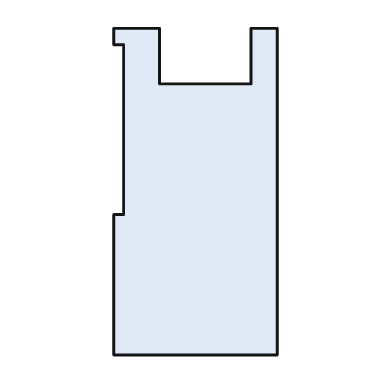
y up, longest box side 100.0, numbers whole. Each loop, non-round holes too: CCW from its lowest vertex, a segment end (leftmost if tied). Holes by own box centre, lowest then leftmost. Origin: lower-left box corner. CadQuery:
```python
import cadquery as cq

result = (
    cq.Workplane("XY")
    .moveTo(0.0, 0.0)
    .lineTo(50.0, 0.0)
    .lineTo(50.0, 100.0)
    .lineTo(42.0, 100.0)
    .lineTo(42.0, 83.0)
    .lineTo(14.0, 83.0)
    .lineTo(14.0, 100.0)
    .lineTo(0.0, 100.0)
    .lineTo(0.0, 95.0)
    .lineTo(3.0, 95.0)
    .lineTo(3.0, 43.0)
    .lineTo(0.0, 43.0)
    .close()
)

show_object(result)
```